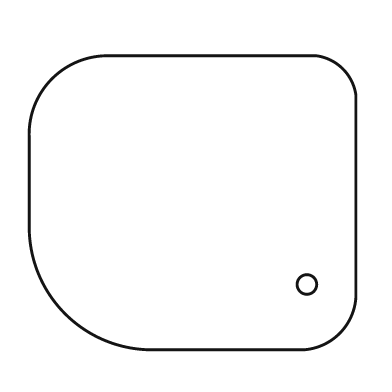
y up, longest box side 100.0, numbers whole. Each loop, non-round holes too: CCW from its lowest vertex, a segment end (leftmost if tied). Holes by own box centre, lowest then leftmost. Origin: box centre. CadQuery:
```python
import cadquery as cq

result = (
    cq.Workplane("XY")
    .moveTo(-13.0, -45.0)
    .lineTo(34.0, -45.0)
    .threePointArc((45.0, -40.0), (50.0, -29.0))
    .lineTo(50.0, 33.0)
    .threePointArc((46.0, 41.0), (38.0, 45.0))
    .lineTo(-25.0, 45.0)
    .threePointArc((-43.0, 38.0), (-50.0, 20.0))
    .lineTo(-50.0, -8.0)
    .threePointArc((-39.0, -34.0), (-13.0, -45.0))
    .close()
    .moveTo(35.0, -25.0)
    .circle(3.0)
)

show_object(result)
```